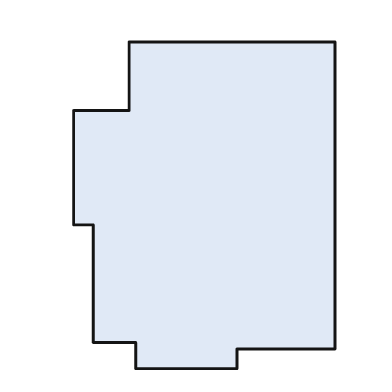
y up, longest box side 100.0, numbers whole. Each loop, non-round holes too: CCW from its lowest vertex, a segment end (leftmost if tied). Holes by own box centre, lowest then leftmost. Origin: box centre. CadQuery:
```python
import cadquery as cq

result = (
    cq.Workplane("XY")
    .moveTo(-21.0, -50.0)
    .lineTo(10.0, -50.0)
    .lineTo(10.0, -44.0)
    .lineTo(40.0, -44.0)
    .lineTo(40.0, 50.0)
    .lineTo(-23.0, 50.0)
    .lineTo(-23.0, 29.0)
    .lineTo(-40.0, 29.0)
    .lineTo(-40.0, -6.0)
    .lineTo(-34.0, -6.0)
    .lineTo(-34.0, -42.0)
    .lineTo(-21.0, -42.0)
    .close()
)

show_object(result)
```